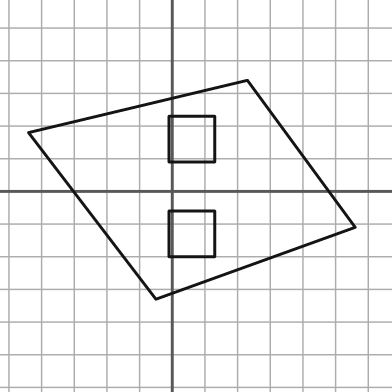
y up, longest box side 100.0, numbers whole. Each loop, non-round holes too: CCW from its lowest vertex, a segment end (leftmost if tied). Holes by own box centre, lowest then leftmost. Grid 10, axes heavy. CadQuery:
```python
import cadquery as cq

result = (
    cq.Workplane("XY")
    .moveTo(-5.0, -33.0)
    .lineTo(56.0, -11.0)
    .lineTo(23.0, 34.0)
    .lineTo(-44.0, 18.0)
    .close()
    .moveTo(-1.0, -20.0)
    .lineTo(13.0, -20.0)
    .lineTo(13.0, -6.0)
    .lineTo(-1.0, -6.0)
    .close()
    .moveTo(-1.0, 9.0)
    .lineTo(13.0, 9.0)
    .lineTo(13.0, 23.0)
    .lineTo(-1.0, 23.0)
    .close()
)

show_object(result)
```